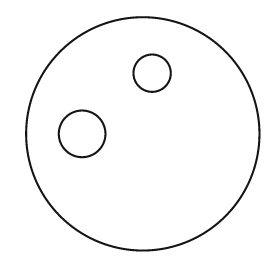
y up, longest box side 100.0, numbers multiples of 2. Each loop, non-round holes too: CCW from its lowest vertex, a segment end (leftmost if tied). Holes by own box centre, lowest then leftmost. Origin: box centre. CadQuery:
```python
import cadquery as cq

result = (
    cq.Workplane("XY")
    .moveTo(0.0, 0.0)
    .circle(50.0)
    .moveTo(-26.0, 0.0)
    .circle(10.0)
    .moveTo(4.0, 26.0)
    .circle(8.0)
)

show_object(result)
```